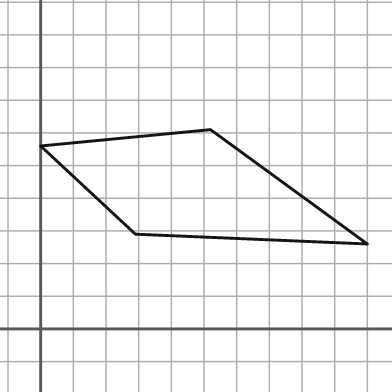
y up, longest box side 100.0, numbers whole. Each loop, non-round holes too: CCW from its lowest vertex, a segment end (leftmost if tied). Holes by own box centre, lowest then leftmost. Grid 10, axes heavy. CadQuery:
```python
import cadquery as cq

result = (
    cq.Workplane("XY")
    .moveTo(100.0, 26.0)
    .lineTo(52.0, 61.0)
    .lineTo(0.0, 56.0)
    .lineTo(29.0, 29.0)
    .close()
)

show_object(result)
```